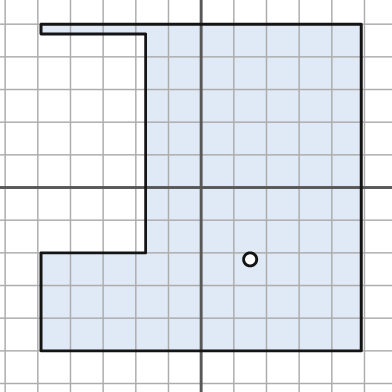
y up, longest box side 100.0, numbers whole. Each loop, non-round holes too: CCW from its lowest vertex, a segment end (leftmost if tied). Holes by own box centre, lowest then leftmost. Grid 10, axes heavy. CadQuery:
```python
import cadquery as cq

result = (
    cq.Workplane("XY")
    .moveTo(-49.0, -50.0)
    .lineTo(49.0, -50.0)
    .lineTo(49.0, 50.0)
    .lineTo(-49.0, 50.0)
    .lineTo(-49.0, 47.0)
    .lineTo(-17.0, 47.0)
    .lineTo(-17.0, -20.0)
    .lineTo(-49.0, -20.0)
    .close()
    .moveTo(15.0, -22.0)
    .circle(2.0)
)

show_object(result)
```